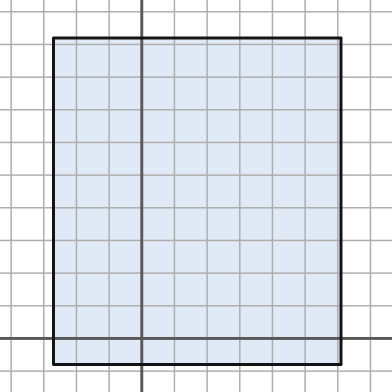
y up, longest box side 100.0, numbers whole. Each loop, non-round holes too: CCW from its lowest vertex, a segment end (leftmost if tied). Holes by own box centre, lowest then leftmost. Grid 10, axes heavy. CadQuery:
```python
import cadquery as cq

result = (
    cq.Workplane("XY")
    .moveTo(-27.0, -8.0)
    .lineTo(61.0, -8.0)
    .lineTo(61.0, 92.0)
    .lineTo(-27.0, 92.0)
    .close()
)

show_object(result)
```